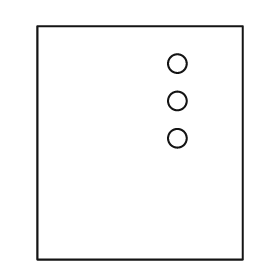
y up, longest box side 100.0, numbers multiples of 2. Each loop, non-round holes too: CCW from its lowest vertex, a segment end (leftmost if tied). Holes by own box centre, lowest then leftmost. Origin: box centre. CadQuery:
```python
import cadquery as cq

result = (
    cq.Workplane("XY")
    .moveTo(-44.0, -50.0)
    .lineTo(44.0, -50.0)
    .lineTo(44.0, 50.0)
    .lineTo(-44.0, 50.0)
    .close()
    .moveTo(16.0, 2.0)
    .circle(4.0)
    .moveTo(16.0, 18.0)
    .circle(4.0)
    .moveTo(16.0, 34.0)
    .circle(4.0)
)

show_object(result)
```